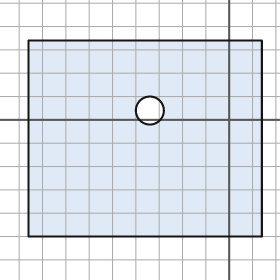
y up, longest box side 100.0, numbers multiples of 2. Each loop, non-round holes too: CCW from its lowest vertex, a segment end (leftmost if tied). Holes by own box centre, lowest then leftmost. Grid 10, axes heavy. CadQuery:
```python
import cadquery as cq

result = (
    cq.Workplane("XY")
    .moveTo(-86.0, -50.0)
    .lineTo(14.0, -50.0)
    .lineTo(14.0, 34.0)
    .lineTo(-86.0, 34.0)
    .close()
    .moveTo(-34.0, 4.0)
    .circle(6.0)
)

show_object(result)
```